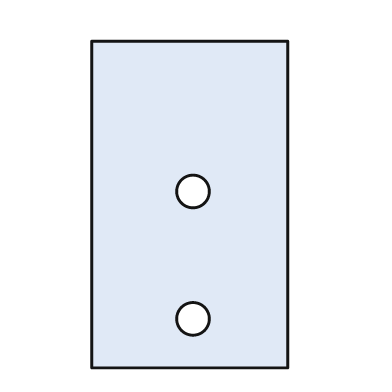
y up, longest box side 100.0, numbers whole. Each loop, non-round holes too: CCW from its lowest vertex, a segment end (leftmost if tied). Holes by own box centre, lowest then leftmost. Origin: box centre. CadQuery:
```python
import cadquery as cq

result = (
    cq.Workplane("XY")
    .moveTo(-30.0, -50.0)
    .lineTo(30.0, -50.0)
    .lineTo(30.0, 50.0)
    .lineTo(-30.0, 50.0)
    .close()
    .moveTo(1.0, -35.0)
    .circle(5.0)
    .moveTo(1.0, 4.0)
    .circle(5.0)
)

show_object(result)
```